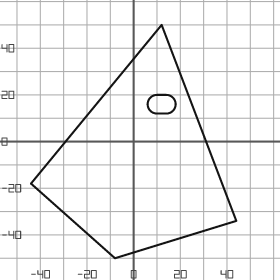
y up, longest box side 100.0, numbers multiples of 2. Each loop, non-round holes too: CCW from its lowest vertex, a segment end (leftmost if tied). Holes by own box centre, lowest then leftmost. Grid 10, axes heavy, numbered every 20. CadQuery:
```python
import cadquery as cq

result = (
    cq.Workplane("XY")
    .moveTo(-8.0, -50.0)
    .lineTo(44.0, -34.0)
    .lineTo(12.0, 50.0)
    .lineTo(-44.0, -18.0)
    .close()
    .moveTo(10.0, 12.0)
    .lineTo(14.0, 12.0)
    .threePointArc((18.0, 16.0), (14.0, 20.0))
    .lineTo(10.0, 20.0)
    .threePointArc((6.0, 16.0), (10.0, 12.0))
    .close()
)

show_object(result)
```